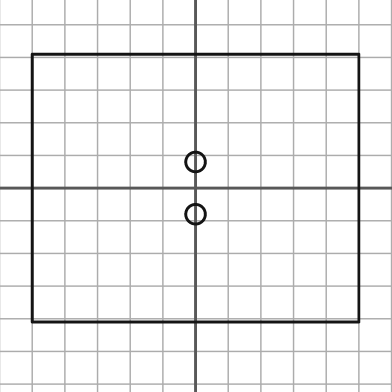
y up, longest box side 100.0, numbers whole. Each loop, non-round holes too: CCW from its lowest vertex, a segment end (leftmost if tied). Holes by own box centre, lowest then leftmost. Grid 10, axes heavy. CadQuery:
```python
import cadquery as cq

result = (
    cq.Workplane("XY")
    .moveTo(-50.0, -41.0)
    .lineTo(50.0, -41.0)
    .lineTo(50.0, 41.0)
    .lineTo(-50.0, 41.0)
    .close()
    .moveTo(0.0, -8.0)
    .circle(3.0)
    .moveTo(0.0, 8.0)
    .circle(3.0)
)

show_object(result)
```